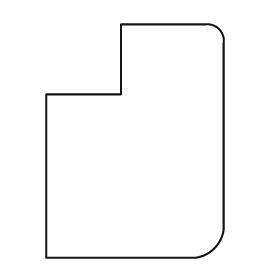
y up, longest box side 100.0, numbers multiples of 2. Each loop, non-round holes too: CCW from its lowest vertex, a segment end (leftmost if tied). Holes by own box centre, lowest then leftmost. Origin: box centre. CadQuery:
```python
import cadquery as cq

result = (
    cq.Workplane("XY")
    .moveTo(-38.0, -50.0)
    .lineTo(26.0, -50.0)
    .threePointArc((34.0, -46.0), (38.0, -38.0))
    .lineTo(38.0, 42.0)
    .threePointArc((36.0, 48.0), (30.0, 50.0))
    .lineTo(-6.0, 50.0)
    .lineTo(-6.0, 20.0)
    .lineTo(-38.0, 20.0)
    .close()
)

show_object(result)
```